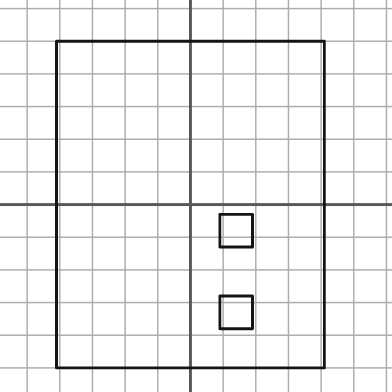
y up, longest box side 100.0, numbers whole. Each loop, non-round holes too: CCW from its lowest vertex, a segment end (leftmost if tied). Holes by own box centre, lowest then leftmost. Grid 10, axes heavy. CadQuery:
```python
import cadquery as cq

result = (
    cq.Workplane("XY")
    .moveTo(-41.0, -50.0)
    .lineTo(41.0, -50.0)
    .lineTo(41.0, 50.0)
    .lineTo(-41.0, 50.0)
    .close()
    .moveTo(9.0, -38.0)
    .lineTo(19.0, -38.0)
    .lineTo(19.0, -28.0)
    .lineTo(9.0, -28.0)
    .close()
    .moveTo(9.0, -13.0)
    .lineTo(19.0, -13.0)
    .lineTo(19.0, -3.0)
    .lineTo(9.0, -3.0)
    .close()
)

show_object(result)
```